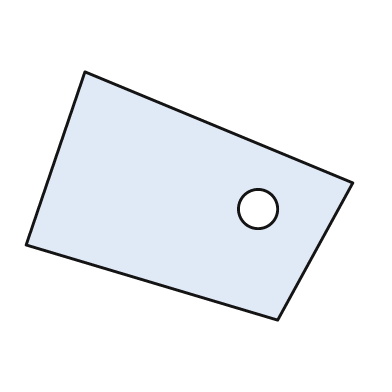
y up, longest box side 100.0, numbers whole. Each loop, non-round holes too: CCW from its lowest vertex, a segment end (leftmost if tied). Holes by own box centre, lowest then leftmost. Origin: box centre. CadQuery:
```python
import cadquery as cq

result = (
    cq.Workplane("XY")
    .moveTo(27.0, -38.0)
    .lineTo(50.0, 4.0)
    .lineTo(-32.0, 38.0)
    .lineTo(-50.0, -15.0)
    .close()
    .moveTo(21.0, -4.0)
    .circle(6.0)
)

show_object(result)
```